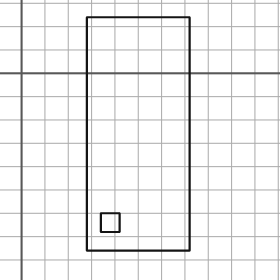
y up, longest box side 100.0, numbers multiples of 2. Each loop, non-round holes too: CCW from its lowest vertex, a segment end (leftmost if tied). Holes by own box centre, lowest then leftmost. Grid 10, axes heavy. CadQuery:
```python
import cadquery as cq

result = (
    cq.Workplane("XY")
    .moveTo(28.0, -76.0)
    .lineTo(72.0, -76.0)
    .lineTo(72.0, 24.0)
    .lineTo(28.0, 24.0)
    .close()
    .moveTo(34.0, -68.0)
    .lineTo(42.0, -68.0)
    .lineTo(42.0, -60.0)
    .lineTo(34.0, -60.0)
    .close()
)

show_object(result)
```